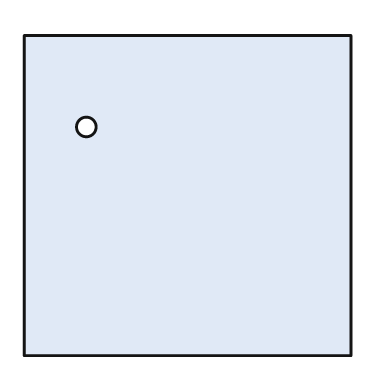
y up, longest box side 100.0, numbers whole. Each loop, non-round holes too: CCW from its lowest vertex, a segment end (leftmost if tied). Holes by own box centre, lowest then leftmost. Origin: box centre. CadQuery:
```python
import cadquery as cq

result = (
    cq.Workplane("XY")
    .moveTo(-50.0, -49.0)
    .lineTo(50.0, -49.0)
    .lineTo(50.0, 49.0)
    .lineTo(-50.0, 49.0)
    .close()
    .moveTo(-31.0, 21.0)
    .circle(3.0)
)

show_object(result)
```